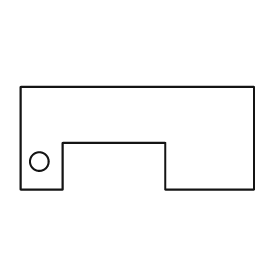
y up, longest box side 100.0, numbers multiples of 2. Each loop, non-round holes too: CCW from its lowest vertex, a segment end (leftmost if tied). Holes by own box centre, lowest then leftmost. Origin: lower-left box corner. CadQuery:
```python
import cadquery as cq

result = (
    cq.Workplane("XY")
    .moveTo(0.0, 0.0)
    .lineTo(18.0, 0.0)
    .lineTo(18.0, 20.0)
    .lineTo(62.0, 20.0)
    .lineTo(62.0, 0.0)
    .lineTo(100.0, 0.0)
    .lineTo(100.0, 44.0)
    .lineTo(0.0, 44.0)
    .close()
    .moveTo(8.0, 12.0)
    .circle(4.0)
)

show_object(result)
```